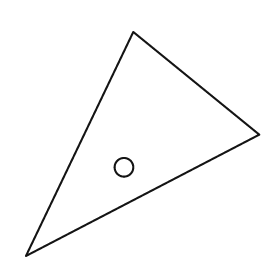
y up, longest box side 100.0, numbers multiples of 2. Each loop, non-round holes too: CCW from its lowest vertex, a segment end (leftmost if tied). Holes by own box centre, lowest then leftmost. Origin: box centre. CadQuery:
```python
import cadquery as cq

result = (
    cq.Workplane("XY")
    .moveTo(-50.0, -48.0)
    .lineTo(50.0, 4.0)
    .lineTo(-4.0, 48.0)
    .close()
    .moveTo(-8.0, -10.0)
    .circle(4.0)
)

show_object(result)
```